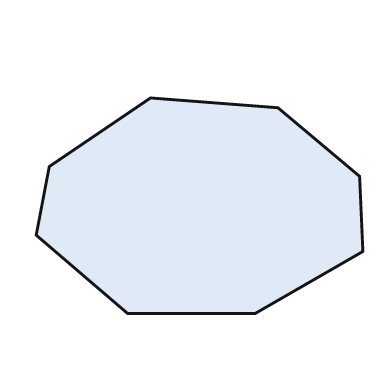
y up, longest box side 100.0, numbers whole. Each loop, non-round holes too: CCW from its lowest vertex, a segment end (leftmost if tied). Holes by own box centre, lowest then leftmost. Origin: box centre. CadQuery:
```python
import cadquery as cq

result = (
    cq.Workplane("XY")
    .moveTo(-22.0, -33.0)
    .lineTo(17.0, -33.0)
    .lineTo(50.0, -14.0)
    .lineTo(49.0, 9.0)
    .lineTo(24.0, 30.0)
    .lineTo(-15.0, 33.0)
    .lineTo(-46.0, 12.0)
    .lineTo(-50.0, -9.0)
    .close()
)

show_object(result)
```